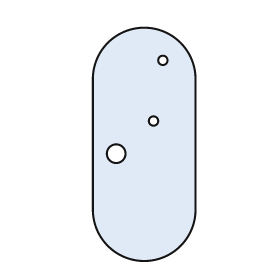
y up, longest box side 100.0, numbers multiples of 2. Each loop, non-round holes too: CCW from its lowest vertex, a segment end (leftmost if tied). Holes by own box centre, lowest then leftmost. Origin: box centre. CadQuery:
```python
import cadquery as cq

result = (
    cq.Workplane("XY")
    .moveTo(-22.0, -28.0)
    .threePointArc((0.0, -50.0), (22.0, -28.0))
    .lineTo(22.0, 28.0)
    .threePointArc((0.0, 50.0), (-22.0, 28.0))
    .close()
    .moveTo(-12.0, -4.0)
    .circle(4.0)
    .moveTo(4.0, 10.0)
    .circle(2.0)
    .moveTo(8.0, 36.0)
    .circle(2.0)
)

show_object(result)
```